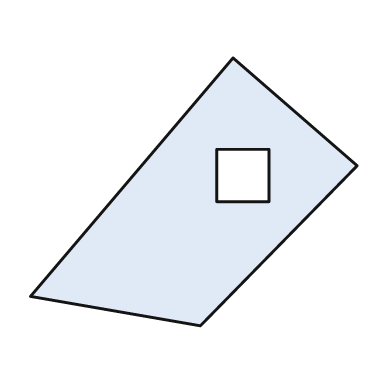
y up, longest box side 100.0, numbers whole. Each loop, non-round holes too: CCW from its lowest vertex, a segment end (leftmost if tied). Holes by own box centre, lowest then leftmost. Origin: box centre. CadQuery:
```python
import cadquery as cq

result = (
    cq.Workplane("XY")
    .moveTo(2.0, -41.0)
    .lineTo(50.0, 8.0)
    .lineTo(12.0, 41.0)
    .lineTo(-50.0, -32.0)
    .close()
    .moveTo(7.0, -3.0)
    .lineTo(23.0, -3.0)
    .lineTo(23.0, 13.0)
    .lineTo(7.0, 13.0)
    .close()
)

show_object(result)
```